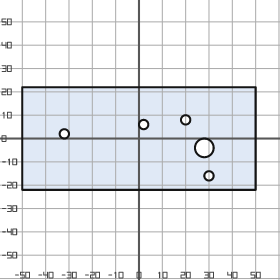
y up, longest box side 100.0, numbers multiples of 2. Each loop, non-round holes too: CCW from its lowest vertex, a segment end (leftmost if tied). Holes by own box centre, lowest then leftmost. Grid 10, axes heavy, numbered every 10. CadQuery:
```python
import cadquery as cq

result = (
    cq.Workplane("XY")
    .moveTo(-50.0, -22.0)
    .lineTo(50.0, -22.0)
    .lineTo(50.0, 22.0)
    .lineTo(-50.0, 22.0)
    .close()
    .moveTo(30.0, -16.0)
    .circle(2.0)
    .moveTo(28.0, -4.0)
    .circle(4.0)
    .moveTo(-32.0, 2.0)
    .circle(2.0)
    .moveTo(2.0, 6.0)
    .circle(2.0)
    .moveTo(20.0, 8.0)
    .circle(2.0)
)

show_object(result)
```